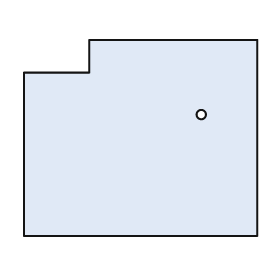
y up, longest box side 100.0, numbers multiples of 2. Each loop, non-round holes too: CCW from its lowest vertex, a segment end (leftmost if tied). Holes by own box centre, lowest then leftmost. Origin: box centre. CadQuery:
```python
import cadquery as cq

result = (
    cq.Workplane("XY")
    .moveTo(-50.0, -42.0)
    .lineTo(50.0, -42.0)
    .lineTo(50.0, 42.0)
    .lineTo(-22.0, 42.0)
    .lineTo(-22.0, 28.0)
    .lineTo(-50.0, 28.0)
    .close()
    .moveTo(26.0, 10.0)
    .circle(2.0)
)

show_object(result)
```